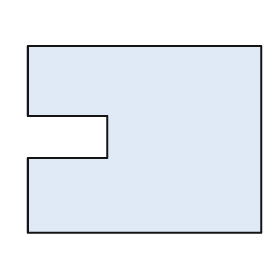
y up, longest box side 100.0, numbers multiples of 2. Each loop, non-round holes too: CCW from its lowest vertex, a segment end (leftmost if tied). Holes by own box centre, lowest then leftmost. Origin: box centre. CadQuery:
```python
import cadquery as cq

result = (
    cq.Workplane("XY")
    .moveTo(-50.0, -40.0)
    .lineTo(50.0, -40.0)
    .lineTo(50.0, 40.0)
    .lineTo(-50.0, 40.0)
    .lineTo(-50.0, 10.0)
    .lineTo(-16.0, 10.0)
    .lineTo(-16.0, -8.0)
    .lineTo(-50.0, -8.0)
    .close()
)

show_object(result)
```